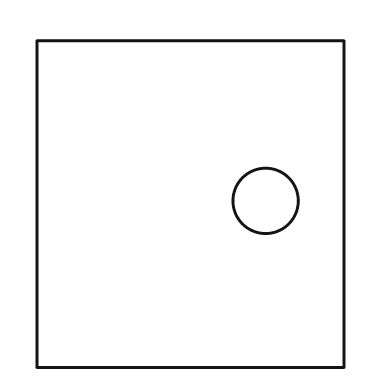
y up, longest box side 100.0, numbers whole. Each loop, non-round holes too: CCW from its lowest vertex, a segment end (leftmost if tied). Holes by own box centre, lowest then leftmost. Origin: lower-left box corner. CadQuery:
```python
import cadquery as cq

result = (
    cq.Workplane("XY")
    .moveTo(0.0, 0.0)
    .lineTo(94.0, 0.0)
    .lineTo(94.0, 100.0)
    .lineTo(0.0, 100.0)
    .close()
    .moveTo(70.0, 51.0)
    .circle(10.0)
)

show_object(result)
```